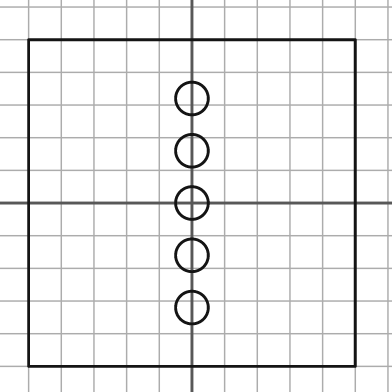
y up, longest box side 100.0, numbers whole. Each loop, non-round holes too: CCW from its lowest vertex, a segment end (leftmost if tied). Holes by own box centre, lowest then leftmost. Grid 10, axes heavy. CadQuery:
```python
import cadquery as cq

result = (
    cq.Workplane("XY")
    .moveTo(-50.0, -50.0)
    .lineTo(50.0, -50.0)
    .lineTo(50.0, 50.0)
    .lineTo(-50.0, 50.0)
    .close()
    .moveTo(0.0, -32.0)
    .circle(5.0)
    .moveTo(0.0, -16.0)
    .circle(5.0)
    .moveTo(0.0, 0.0)
    .circle(5.0)
    .moveTo(0.0, 16.0)
    .circle(5.0)
    .moveTo(0.0, 32.0)
    .circle(5.0)
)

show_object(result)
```